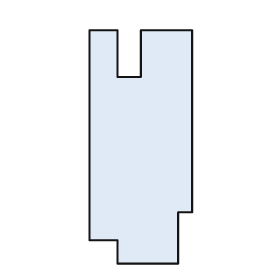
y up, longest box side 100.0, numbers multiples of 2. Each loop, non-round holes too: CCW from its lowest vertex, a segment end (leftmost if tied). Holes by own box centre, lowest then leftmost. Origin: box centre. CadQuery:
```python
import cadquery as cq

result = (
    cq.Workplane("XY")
    .moveTo(-10.0, -50.0)
    .lineTo(16.0, -50.0)
    .lineTo(16.0, -28.0)
    .lineTo(22.0, -28.0)
    .lineTo(22.0, 50.0)
    .lineTo(0.0, 50.0)
    .lineTo(0.0, 30.0)
    .lineTo(-10.0, 30.0)
    .lineTo(-10.0, 50.0)
    .lineTo(-22.0, 50.0)
    .lineTo(-22.0, -40.0)
    .lineTo(-10.0, -40.0)
    .close()
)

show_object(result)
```